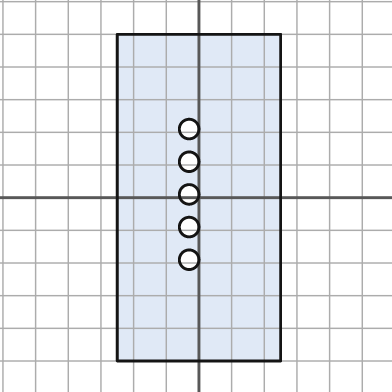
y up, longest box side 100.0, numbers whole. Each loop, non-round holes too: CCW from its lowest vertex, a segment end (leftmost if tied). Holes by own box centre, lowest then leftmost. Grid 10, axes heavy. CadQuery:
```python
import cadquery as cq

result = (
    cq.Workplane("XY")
    .moveTo(-25.0, -50.0)
    .lineTo(25.0, -50.0)
    .lineTo(25.0, 50.0)
    .lineTo(-25.0, 50.0)
    .close()
    .moveTo(-3.0, -19.0)
    .circle(3.0)
    .moveTo(-3.0, -9.0)
    .circle(3.0)
    .moveTo(-3.0, 1.0)
    .circle(3.0)
    .moveTo(-3.0, 11.0)
    .circle(3.0)
    .moveTo(-3.0, 21.0)
    .circle(3.0)
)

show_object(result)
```